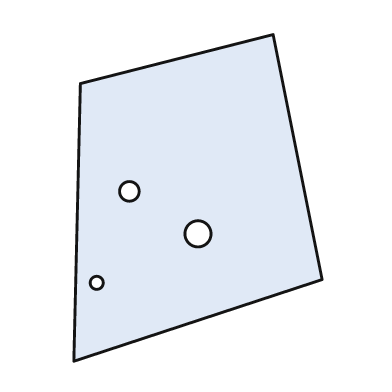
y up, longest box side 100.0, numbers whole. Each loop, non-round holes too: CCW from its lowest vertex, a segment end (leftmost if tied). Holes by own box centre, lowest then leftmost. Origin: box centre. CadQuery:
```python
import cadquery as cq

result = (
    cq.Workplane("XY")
    .moveTo(-38.0, -50.0)
    .lineTo(38.0, -25.0)
    .lineTo(23.0, 50.0)
    .lineTo(-36.0, 35.0)
    .close()
    .moveTo(-31.0, -26.0)
    .circle(2.0)
    .moveTo(0.0, -11.0)
    .circle(4.0)
    .moveTo(-21.0, 2.0)
    .circle(3.0)
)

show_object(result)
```